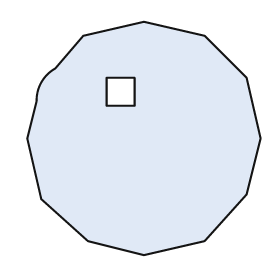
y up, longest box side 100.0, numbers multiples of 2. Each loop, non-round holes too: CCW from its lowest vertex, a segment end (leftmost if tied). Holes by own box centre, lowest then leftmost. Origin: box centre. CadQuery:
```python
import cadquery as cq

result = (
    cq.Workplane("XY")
    .moveTo(0.0, -50.0)
    .lineTo(26.0, -44.0)
    .lineTo(44.0, -24.0)
    .lineTo(50.0, 0.0)
    .lineTo(44.0, 26.0)
    .lineTo(26.0, 44.0)
    .lineTo(0.0, 50.0)
    .lineTo(-26.0, 44.0)
    .lineTo(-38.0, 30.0)
    .threePointArc((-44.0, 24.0), (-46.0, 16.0))
    .lineTo(-50.0, 0.0)
    .lineTo(-44.0, -26.0)
    .lineTo(-24.0, -44.0)
    .close()
    .moveTo(-16.0, 14.0)
    .lineTo(-4.0, 14.0)
    .lineTo(-4.0, 26.0)
    .lineTo(-16.0, 26.0)
    .close()
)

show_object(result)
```